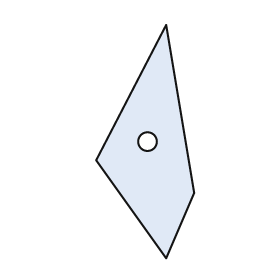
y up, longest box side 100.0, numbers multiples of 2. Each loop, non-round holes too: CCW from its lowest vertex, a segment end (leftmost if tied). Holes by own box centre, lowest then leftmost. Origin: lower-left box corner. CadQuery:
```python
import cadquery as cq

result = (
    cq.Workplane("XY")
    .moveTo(30.0, 0.0)
    .lineTo(42.0, 28.0)
    .lineTo(30.0, 100.0)
    .lineTo(0.0, 42.0)
    .close()
    .moveTo(22.0, 50.0)
    .circle(4.0)
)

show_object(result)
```